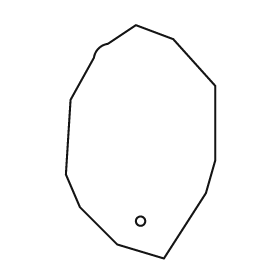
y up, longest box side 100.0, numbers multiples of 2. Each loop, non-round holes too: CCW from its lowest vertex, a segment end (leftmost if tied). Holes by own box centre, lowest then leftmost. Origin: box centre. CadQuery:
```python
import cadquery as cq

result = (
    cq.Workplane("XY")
    .moveTo(10.0, -50.0)
    .lineTo(28.0, -22.0)
    .lineTo(32.0, -8.0)
    .lineTo(32.0, 24.0)
    .lineTo(14.0, 44.0)
    .lineTo(-2.0, 50.0)
    .lineTo(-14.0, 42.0)
    .threePointArc((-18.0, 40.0), (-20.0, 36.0))
    .lineTo(-30.0, 18.0)
    .lineTo(-32.0, -14.0)
    .lineTo(-26.0, -28.0)
    .lineTo(-10.0, -44.0)
    .close()
    .moveTo(0.0, -34.0)
    .circle(2.0)
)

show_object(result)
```